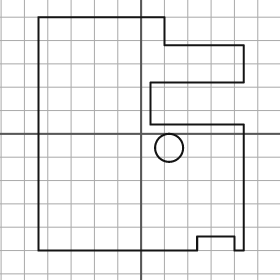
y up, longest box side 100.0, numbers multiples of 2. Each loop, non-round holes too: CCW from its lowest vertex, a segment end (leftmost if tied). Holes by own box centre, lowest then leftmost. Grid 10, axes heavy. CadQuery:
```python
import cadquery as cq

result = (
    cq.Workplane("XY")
    .moveTo(-44.0, -50.0)
    .lineTo(24.0, -50.0)
    .lineTo(24.0, -44.0)
    .lineTo(40.0, -44.0)
    .lineTo(40.0, -50.0)
    .lineTo(44.0, -50.0)
    .lineTo(44.0, 4.0)
    .lineTo(4.0, 4.0)
    .lineTo(4.0, 22.0)
    .lineTo(44.0, 22.0)
    .lineTo(44.0, 38.0)
    .lineTo(10.0, 38.0)
    .lineTo(10.0, 50.0)
    .lineTo(-44.0, 50.0)
    .close()
    .moveTo(12.0, -6.0)
    .circle(6.0)
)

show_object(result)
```